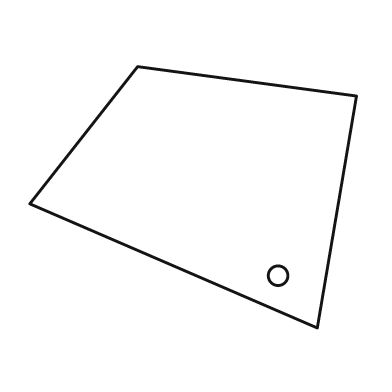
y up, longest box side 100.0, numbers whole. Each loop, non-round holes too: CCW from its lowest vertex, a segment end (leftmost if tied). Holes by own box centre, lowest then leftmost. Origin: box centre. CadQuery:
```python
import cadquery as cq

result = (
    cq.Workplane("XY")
    .moveTo(38.0, -40.0)
    .lineTo(50.0, 31.0)
    .lineTo(-17.0, 40.0)
    .lineTo(-50.0, -2.0)
    .close()
    .moveTo(26.0, -24.0)
    .circle(3.0)
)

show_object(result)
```